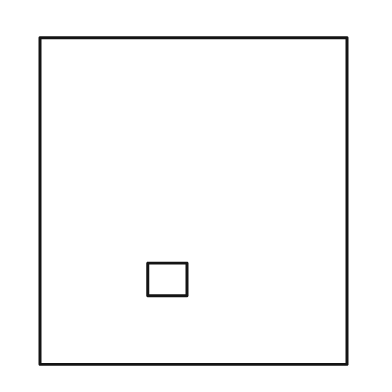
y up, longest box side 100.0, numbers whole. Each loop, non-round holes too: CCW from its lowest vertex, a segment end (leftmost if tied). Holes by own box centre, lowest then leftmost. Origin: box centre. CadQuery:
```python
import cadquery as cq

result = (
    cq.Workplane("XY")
    .moveTo(-47.0, -50.0)
    .lineTo(47.0, -50.0)
    .lineTo(47.0, 50.0)
    .lineTo(-47.0, 50.0)
    .close()
    .moveTo(-14.0, -29.0)
    .lineTo(-2.0, -29.0)
    .lineTo(-2.0, -19.0)
    .lineTo(-14.0, -19.0)
    .close()
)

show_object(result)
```